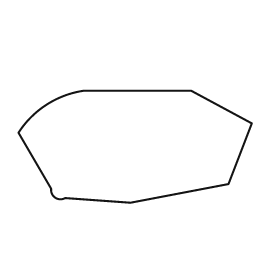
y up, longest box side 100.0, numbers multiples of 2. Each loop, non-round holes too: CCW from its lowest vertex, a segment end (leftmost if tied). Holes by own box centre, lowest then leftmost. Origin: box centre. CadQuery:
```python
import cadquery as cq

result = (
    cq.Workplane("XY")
    .moveTo(-2.0, -24.0)
    .lineTo(40.0, -16.0)
    .lineTo(50.0, 10.0)
    .lineTo(24.0, 24.0)
    .lineTo(-22.0, 24.0)
    .threePointArc((-38.0, 18.0), (-50.0, 6.0))
    .lineTo(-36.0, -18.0)
    .threePointArc((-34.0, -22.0), (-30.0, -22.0))
    .close()
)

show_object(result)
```